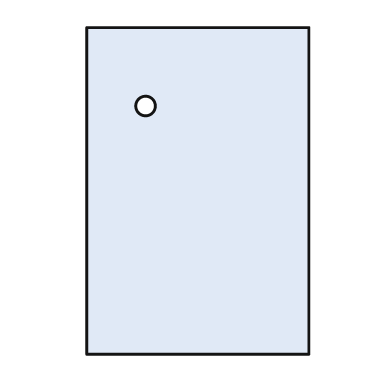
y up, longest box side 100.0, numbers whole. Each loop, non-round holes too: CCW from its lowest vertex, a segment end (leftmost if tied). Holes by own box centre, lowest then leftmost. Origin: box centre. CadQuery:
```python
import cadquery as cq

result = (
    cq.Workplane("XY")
    .moveTo(-34.0, -50.0)
    .lineTo(34.0, -50.0)
    .lineTo(34.0, 50.0)
    .lineTo(-34.0, 50.0)
    .close()
    .moveTo(-16.0, 26.0)
    .circle(3.0)
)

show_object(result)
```